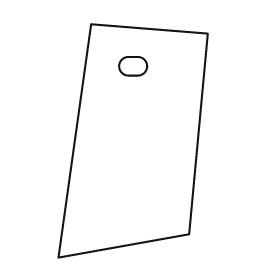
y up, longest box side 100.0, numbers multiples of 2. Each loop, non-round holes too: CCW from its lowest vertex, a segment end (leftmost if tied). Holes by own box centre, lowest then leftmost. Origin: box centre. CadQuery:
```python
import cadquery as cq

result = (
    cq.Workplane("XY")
    .moveTo(-32.0, -50.0)
    .lineTo(24.0, -40.0)
    .lineTo(32.0, 46.0)
    .lineTo(-18.0, 50.0)
    .close()
    .moveTo(-2.0, 28.0)
    .lineTo(2.0, 28.0)
    .threePointArc((6.0, 32.0), (2.0, 36.0))
    .lineTo(-2.0, 36.0)
    .threePointArc((-6.0, 32.0), (-2.0, 28.0))
    .close()
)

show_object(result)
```